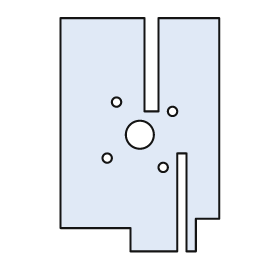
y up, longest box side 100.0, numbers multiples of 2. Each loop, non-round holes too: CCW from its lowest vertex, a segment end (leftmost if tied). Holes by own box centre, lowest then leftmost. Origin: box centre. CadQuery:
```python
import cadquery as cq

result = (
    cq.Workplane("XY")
    .moveTo(-4.0, -50.0)
    .lineTo(16.0, -50.0)
    .lineTo(16.0, -8.0)
    .lineTo(20.0, -8.0)
    .lineTo(20.0, -50.0)
    .lineTo(24.0, -50.0)
    .lineTo(24.0, -36.0)
    .lineTo(34.0, -36.0)
    .lineTo(34.0, 50.0)
    .lineTo(8.0, 50.0)
    .lineTo(8.0, 10.0)
    .lineTo(2.0, 10.0)
    .lineTo(2.0, 50.0)
    .lineTo(-34.0, 50.0)
    .lineTo(-34.0, -40.0)
    .lineTo(-4.0, -40.0)
    .close()
    .moveTo(10.0, -14.0)
    .circle(2.0)
    .moveTo(-14.0, -10.0)
    .circle(2.0)
    .moveTo(0.0, 0.0)
    .circle(6.0)
    .moveTo(14.0, 10.0)
    .circle(2.0)
    .moveTo(-10.0, 14.0)
    .circle(2.0)
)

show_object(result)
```